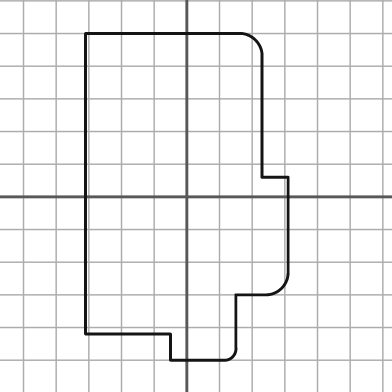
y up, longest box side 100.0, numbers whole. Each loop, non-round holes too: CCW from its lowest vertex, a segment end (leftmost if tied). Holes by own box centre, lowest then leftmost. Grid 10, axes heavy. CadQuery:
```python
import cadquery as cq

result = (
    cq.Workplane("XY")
    .moveTo(-5.0, -50.0)
    .lineTo(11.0, -50.0)
    .threePointArc((14.0, -49.0), (15.0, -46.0))
    .lineTo(15.0, -30.0)
    .lineTo(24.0, -30.0)
    .threePointArc((29.0, -28.0), (31.0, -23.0))
    .lineTo(31.0, 6.0)
    .lineTo(23.0, 6.0)
    .lineTo(23.0, 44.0)
    .threePointArc((21.0, 48.0), (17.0, 50.0))
    .lineTo(-31.0, 50.0)
    .lineTo(-31.0, -42.0)
    .lineTo(-5.0, -42.0)
    .close()
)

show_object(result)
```